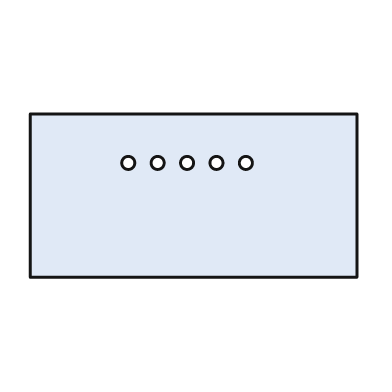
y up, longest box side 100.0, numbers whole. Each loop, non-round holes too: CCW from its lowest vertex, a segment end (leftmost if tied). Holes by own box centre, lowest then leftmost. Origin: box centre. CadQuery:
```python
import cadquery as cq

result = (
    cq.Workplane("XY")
    .moveTo(-50.0, -25.0)
    .lineTo(50.0, -25.0)
    .lineTo(50.0, 25.0)
    .lineTo(-50.0, 25.0)
    .close()
    .moveTo(-20.0, 10.0)
    .circle(2.0)
    .moveTo(-11.0, 10.0)
    .circle(2.0)
    .moveTo(-2.0, 10.0)
    .circle(2.0)
    .moveTo(7.0, 10.0)
    .circle(2.0)
    .moveTo(16.0, 10.0)
    .circle(2.0)
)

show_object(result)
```